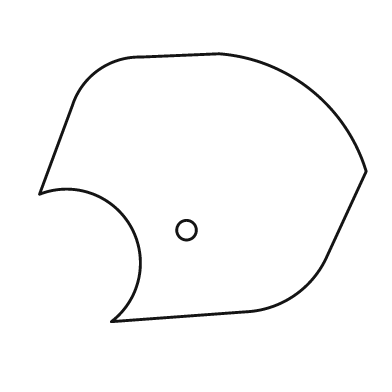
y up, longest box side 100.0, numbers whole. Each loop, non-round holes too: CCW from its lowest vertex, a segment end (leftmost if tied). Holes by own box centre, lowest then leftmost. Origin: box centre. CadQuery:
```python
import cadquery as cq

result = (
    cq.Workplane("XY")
    .moveTo(-28.0, -41.0)
    .lineTo(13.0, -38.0)
    .threePointArc((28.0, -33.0), (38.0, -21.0))
    .lineTo(50.0, 5.0)
    .threePointArc((33.0, 30.0), (5.0, 41.0))
    .lineTo(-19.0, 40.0)
    .threePointArc((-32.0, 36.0), (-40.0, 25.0))
    .lineTo(-50.0, -2.0)
    .threePointArc((-22.0, -12.0), (-28.0, -41.0))
    .close()
    .moveTo(-5.0, -13.0)
    .circle(3.0)
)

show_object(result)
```